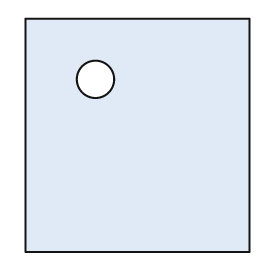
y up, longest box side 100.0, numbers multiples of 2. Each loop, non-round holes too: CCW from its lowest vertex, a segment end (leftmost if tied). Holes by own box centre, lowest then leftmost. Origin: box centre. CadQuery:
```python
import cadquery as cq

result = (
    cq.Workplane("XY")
    .moveTo(-48.0, -50.0)
    .lineTo(48.0, -50.0)
    .lineTo(48.0, 50.0)
    .lineTo(-48.0, 50.0)
    .close()
    .moveTo(-18.0, 24.0)
    .circle(8.0)
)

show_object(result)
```